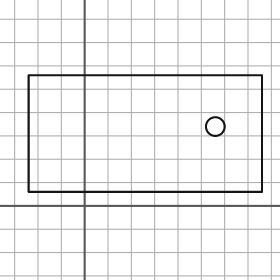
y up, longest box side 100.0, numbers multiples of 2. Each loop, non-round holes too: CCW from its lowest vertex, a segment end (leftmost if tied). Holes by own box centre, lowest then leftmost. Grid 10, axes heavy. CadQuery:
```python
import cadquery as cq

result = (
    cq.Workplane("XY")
    .moveTo(-24.0, 6.0)
    .lineTo(76.0, 6.0)
    .lineTo(76.0, 56.0)
    .lineTo(-24.0, 56.0)
    .close()
    .moveTo(56.0, 34.0)
    .circle(4.0)
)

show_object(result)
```